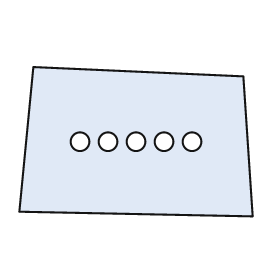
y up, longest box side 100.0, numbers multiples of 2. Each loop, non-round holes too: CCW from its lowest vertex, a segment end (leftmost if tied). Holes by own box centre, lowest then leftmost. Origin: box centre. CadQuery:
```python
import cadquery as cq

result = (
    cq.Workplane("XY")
    .moveTo(50.0, -32.0)
    .lineTo(46.0, 28.0)
    .lineTo(-44.0, 32.0)
    .lineTo(-50.0, -30.0)
    .close()
    .moveTo(-24.0, 0.0)
    .circle(4.0)
    .moveTo(-12.0, 0.0)
    .circle(4.0)
    .moveTo(0.0, 0.0)
    .circle(4.0)
    .moveTo(12.0, 0.0)
    .circle(4.0)
    .moveTo(24.0, 0.0)
    .circle(4.0)
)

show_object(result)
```